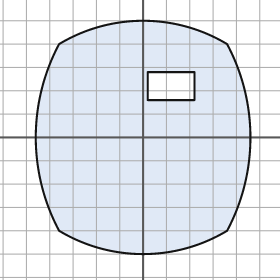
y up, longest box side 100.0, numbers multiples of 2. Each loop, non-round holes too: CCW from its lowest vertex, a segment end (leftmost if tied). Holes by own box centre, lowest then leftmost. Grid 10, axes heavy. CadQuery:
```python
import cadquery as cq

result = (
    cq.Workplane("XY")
    .moveTo(-36.0, -40.0)
    .threePointArc((0.0, -50.0), (36.0, -40.0))
    .threePointArc((46.0, 0.0), (36.0, 40.0))
    .threePointArc((0.0, 50.0), (-36.0, 40.0))
    .threePointArc((-46.0, 0.0), (-36.0, -40.0))
    .close()
    .moveTo(2.0, 16.0)
    .lineTo(22.0, 16.0)
    .lineTo(22.0, 28.0)
    .lineTo(2.0, 28.0)
    .close()
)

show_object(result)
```